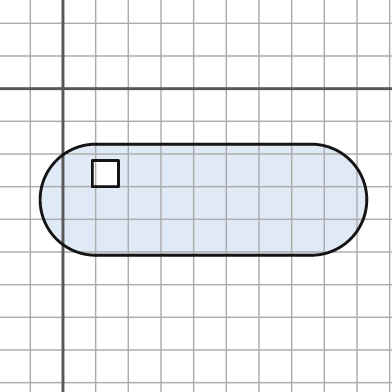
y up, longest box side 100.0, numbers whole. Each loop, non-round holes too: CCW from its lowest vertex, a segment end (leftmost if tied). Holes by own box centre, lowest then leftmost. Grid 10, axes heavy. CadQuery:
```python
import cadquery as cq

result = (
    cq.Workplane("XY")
    .moveTo(10.0, -51.0)
    .lineTo(76.0, -51.0)
    .threePointArc((93.0, -34.0), (76.0, -17.0))
    .lineTo(10.0, -17.0)
    .threePointArc((-7.0, -34.0), (10.0, -51.0))
    .close()
    .moveTo(9.0, -30.0)
    .lineTo(17.0, -30.0)
    .lineTo(17.0, -22.0)
    .lineTo(9.0, -22.0)
    .close()
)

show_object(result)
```